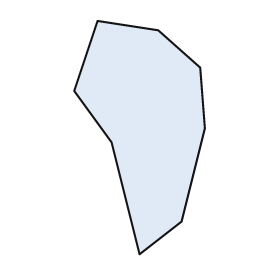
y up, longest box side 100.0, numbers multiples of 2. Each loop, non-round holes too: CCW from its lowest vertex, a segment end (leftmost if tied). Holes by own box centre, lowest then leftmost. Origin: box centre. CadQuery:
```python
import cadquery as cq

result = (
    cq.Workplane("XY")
    .moveTo(0.0, -50.0)
    .lineTo(18.0, -36.0)
    .lineTo(28.0, 4.0)
    .lineTo(26.0, 30.0)
    .lineTo(8.0, 46.0)
    .lineTo(-18.0, 50.0)
    .lineTo(-28.0, 20.0)
    .lineTo(-12.0, -2.0)
    .close()
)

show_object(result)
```